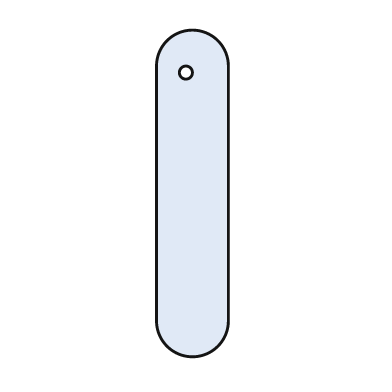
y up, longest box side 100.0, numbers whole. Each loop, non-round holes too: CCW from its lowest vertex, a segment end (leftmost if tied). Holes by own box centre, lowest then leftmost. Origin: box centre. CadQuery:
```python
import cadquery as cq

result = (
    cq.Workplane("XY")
    .moveTo(-11.0, -39.0)
    .threePointArc((0.0, -50.0), (11.0, -39.0))
    .lineTo(11.0, 39.0)
    .threePointArc((0.0, 50.0), (-11.0, 39.0))
    .close()
    .moveTo(-2.0, 37.0)
    .circle(2.0)
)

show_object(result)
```